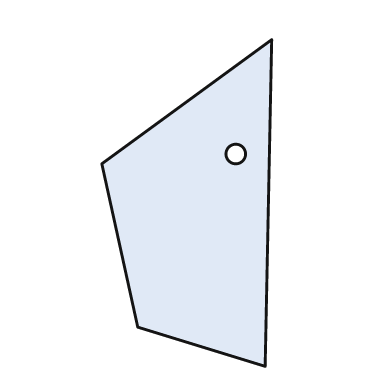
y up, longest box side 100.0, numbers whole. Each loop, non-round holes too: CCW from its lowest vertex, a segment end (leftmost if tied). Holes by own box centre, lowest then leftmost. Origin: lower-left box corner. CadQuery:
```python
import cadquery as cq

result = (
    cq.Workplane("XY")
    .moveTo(50.0, 0.0)
    .lineTo(52.0, 100.0)
    .lineTo(0.0, 62.0)
    .lineTo(11.0, 12.0)
    .close()
    .moveTo(41.0, 65.0)
    .circle(3.0)
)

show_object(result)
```